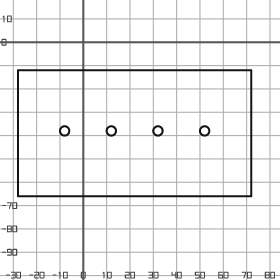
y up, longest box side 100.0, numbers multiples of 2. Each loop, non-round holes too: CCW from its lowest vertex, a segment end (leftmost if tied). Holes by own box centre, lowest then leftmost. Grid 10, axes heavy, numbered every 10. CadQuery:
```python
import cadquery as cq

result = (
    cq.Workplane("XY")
    .moveTo(-28.0, -66.0)
    .lineTo(72.0, -66.0)
    .lineTo(72.0, -12.0)
    .lineTo(-28.0, -12.0)
    .close()
    .moveTo(-8.0, -38.0)
    .circle(2.0)
    .moveTo(12.0, -38.0)
    .circle(2.0)
    .moveTo(32.0, -38.0)
    .circle(2.0)
    .moveTo(52.0, -38.0)
    .circle(2.0)
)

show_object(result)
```